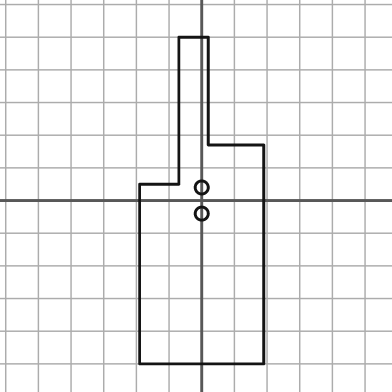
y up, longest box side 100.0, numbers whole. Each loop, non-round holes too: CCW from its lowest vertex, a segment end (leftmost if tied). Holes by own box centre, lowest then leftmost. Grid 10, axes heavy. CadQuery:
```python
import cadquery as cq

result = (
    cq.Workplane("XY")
    .moveTo(-19.0, -50.0)
    .lineTo(19.0, -50.0)
    .lineTo(19.0, 17.0)
    .lineTo(2.0, 17.0)
    .lineTo(2.0, 50.0)
    .lineTo(-7.0, 50.0)
    .lineTo(-7.0, 5.0)
    .lineTo(-19.0, 5.0)
    .close()
    .moveTo(0.0, -4.0)
    .circle(2.0)
    .moveTo(0.0, 4.0)
    .circle(2.0)
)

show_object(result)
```